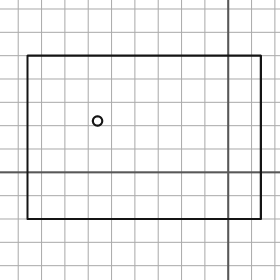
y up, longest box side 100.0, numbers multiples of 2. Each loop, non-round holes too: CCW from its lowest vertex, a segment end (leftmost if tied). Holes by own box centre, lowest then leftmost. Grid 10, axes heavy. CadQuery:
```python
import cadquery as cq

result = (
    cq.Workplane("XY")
    .moveTo(-86.0, -20.0)
    .lineTo(14.0, -20.0)
    .lineTo(14.0, 50.0)
    .lineTo(-86.0, 50.0)
    .close()
    .moveTo(-56.0, 22.0)
    .circle(2.0)
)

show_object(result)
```